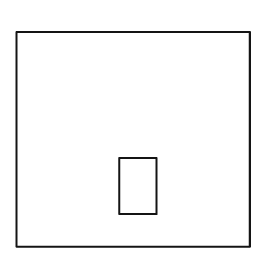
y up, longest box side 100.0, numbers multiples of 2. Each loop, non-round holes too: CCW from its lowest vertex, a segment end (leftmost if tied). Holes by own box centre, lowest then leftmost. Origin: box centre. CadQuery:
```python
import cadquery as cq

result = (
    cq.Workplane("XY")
    .moveTo(-50.0, -46.0)
    .lineTo(50.0, -46.0)
    .lineTo(50.0, 46.0)
    .lineTo(-50.0, 46.0)
    .close()
    .moveTo(-6.0, -32.0)
    .lineTo(10.0, -32.0)
    .lineTo(10.0, -8.0)
    .lineTo(-6.0, -8.0)
    .close()
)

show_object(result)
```